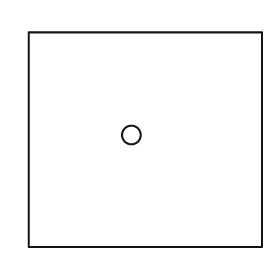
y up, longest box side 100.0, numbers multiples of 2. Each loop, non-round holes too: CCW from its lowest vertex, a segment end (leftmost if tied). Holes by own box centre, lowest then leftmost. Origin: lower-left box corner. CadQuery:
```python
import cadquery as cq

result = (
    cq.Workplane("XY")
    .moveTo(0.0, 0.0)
    .lineTo(100.0, 0.0)
    .lineTo(100.0, 92.0)
    .lineTo(0.0, 92.0)
    .close()
    .moveTo(44.0, 48.0)
    .circle(4.0)
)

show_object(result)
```